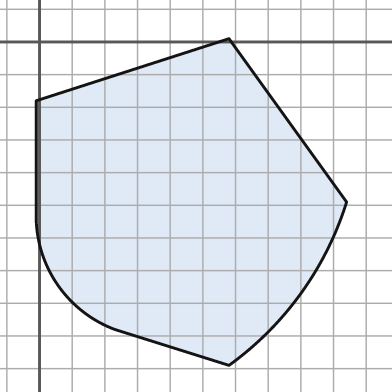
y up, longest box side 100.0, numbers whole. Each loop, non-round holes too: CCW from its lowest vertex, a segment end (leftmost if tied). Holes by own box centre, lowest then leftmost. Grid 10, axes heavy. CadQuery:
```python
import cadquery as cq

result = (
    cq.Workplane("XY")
    .moveTo(58.0, -99.0)
    .threePointArc((80.0, -77.0), (94.0, -49.0))
    .lineTo(58.0, 1.0)
    .lineTo(-1.0, -18.0)
    .lineTo(-1.0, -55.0)
    .threePointArc((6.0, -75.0), (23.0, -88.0))
    .close()
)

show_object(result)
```